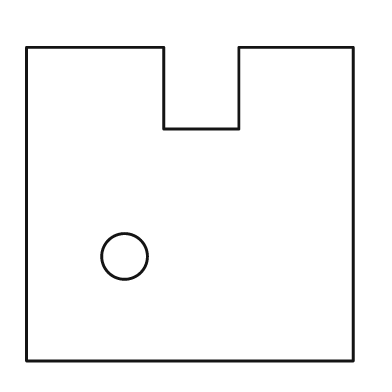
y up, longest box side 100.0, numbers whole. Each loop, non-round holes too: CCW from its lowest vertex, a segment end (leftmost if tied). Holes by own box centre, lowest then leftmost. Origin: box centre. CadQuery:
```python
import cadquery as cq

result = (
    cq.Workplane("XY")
    .moveTo(-50.0, -48.0)
    .lineTo(50.0, -48.0)
    .lineTo(50.0, 48.0)
    .lineTo(15.0, 48.0)
    .lineTo(15.0, 23.0)
    .lineTo(-8.0, 23.0)
    .lineTo(-8.0, 48.0)
    .lineTo(-50.0, 48.0)
    .close()
    .moveTo(-20.0, -16.0)
    .circle(7.0)
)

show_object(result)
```